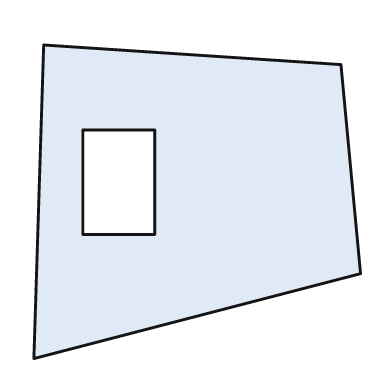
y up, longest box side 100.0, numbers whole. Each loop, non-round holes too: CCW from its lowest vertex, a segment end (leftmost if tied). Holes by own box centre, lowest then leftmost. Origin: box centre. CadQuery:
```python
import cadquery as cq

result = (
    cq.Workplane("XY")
    .moveTo(-50.0, -48.0)
    .lineTo(50.0, -22.0)
    .lineTo(44.0, 42.0)
    .lineTo(-47.0, 48.0)
    .close()
    .moveTo(-35.0, -10.0)
    .lineTo(-13.0, -10.0)
    .lineTo(-13.0, 22.0)
    .lineTo(-35.0, 22.0)
    .close()
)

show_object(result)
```